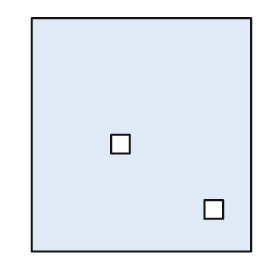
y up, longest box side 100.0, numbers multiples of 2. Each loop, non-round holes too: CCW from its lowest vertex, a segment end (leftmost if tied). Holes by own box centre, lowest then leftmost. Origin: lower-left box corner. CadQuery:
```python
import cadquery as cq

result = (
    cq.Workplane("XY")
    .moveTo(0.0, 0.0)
    .lineTo(94.0, 0.0)
    .lineTo(94.0, 100.0)
    .lineTo(0.0, 100.0)
    .close()
    .moveTo(74.0, 14.0)
    .lineTo(82.0, 14.0)
    .lineTo(82.0, 22.0)
    .lineTo(74.0, 22.0)
    .close()
    .moveTo(34.0, 42.0)
    .lineTo(42.0, 42.0)
    .lineTo(42.0, 50.0)
    .lineTo(34.0, 50.0)
    .close()
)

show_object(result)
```